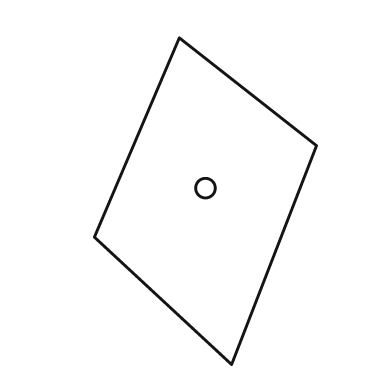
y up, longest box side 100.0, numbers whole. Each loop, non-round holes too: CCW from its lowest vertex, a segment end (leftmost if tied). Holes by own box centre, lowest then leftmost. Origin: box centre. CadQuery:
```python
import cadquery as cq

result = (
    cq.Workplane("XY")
    .moveTo(8.0, -50.0)
    .lineTo(34.0, 17.0)
    .lineTo(-8.0, 50.0)
    .lineTo(-34.0, -11.0)
    .close()
    .moveTo(0.0, 4.0)
    .circle(3.0)
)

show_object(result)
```